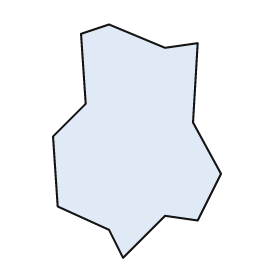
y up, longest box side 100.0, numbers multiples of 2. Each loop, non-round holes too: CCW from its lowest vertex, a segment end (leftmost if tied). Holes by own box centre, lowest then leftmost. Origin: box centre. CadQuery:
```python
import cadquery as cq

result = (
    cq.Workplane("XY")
    .moveTo(-6.0, -50.0)
    .lineTo(12.0, -32.0)
    .lineTo(26.0, -34.0)
    .lineTo(36.0, -14.0)
    .lineTo(24.0, 8.0)
    .lineTo(26.0, 42.0)
    .lineTo(12.0, 40.0)
    .lineTo(-12.0, 50.0)
    .lineTo(-24.0, 46.0)
    .lineTo(-22.0, 16.0)
    .lineTo(-36.0, 2.0)
    .lineTo(-34.0, -28.0)
    .lineTo(-12.0, -38.0)
    .close()
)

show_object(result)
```